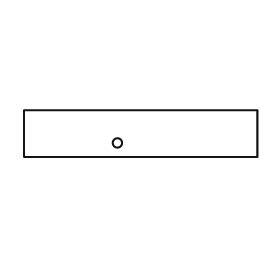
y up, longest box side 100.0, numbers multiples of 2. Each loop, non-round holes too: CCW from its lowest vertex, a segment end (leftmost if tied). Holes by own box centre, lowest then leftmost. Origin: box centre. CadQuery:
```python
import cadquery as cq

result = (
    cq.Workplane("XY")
    .moveTo(-50.0, -10.0)
    .lineTo(50.0, -10.0)
    .lineTo(50.0, 10.0)
    .lineTo(-50.0, 10.0)
    .close()
    .moveTo(-10.0, -4.0)
    .circle(2.0)
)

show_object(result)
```